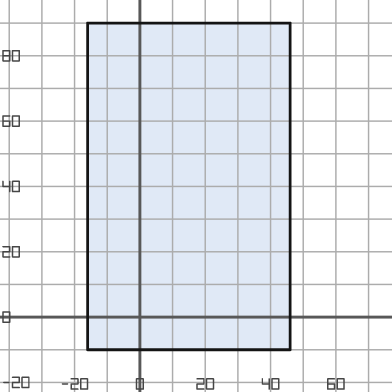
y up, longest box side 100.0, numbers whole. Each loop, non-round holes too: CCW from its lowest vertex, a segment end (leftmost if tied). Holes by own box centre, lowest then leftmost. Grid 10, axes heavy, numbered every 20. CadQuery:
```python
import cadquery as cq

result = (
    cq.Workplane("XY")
    .moveTo(-16.0, -10.0)
    .lineTo(46.0, -10.0)
    .lineTo(46.0, 90.0)
    .lineTo(-16.0, 90.0)
    .close()
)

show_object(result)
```